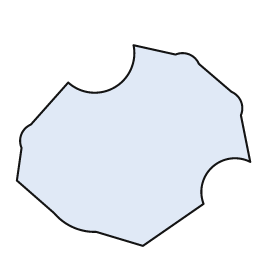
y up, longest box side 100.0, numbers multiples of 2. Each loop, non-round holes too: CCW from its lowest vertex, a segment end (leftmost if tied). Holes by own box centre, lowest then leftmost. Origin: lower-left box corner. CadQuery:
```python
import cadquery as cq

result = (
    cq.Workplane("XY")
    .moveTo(54.0, 0.0)
    .lineTo(80.0, 18.0)
    .threePointArc((84.0, 34.0), (100.0, 36.0))
    .lineTo(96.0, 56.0)
    .threePointArc((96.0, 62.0), (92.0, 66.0))
    .lineTo(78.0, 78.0)
    .threePointArc((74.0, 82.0), (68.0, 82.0))
    .lineTo(50.0, 86.0)
    .threePointArc((42.0, 68.0), (22.0, 70.0))
    .lineTo(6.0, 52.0)
    .threePointArc((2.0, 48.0), (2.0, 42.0))
    .lineTo(0.0, 28.0)
    .lineTo(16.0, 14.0)
    .threePointArc((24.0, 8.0), (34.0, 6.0))
    .close()
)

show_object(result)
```